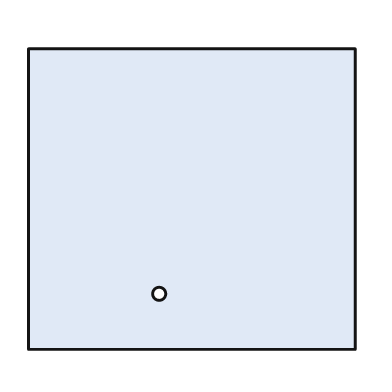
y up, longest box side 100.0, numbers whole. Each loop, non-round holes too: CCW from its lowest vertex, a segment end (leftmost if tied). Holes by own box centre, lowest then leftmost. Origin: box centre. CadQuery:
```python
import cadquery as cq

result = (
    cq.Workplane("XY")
    .moveTo(-50.0, -46.0)
    .lineTo(50.0, -46.0)
    .lineTo(50.0, 46.0)
    .lineTo(-50.0, 46.0)
    .close()
    .moveTo(-10.0, -29.0)
    .circle(2.0)
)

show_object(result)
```